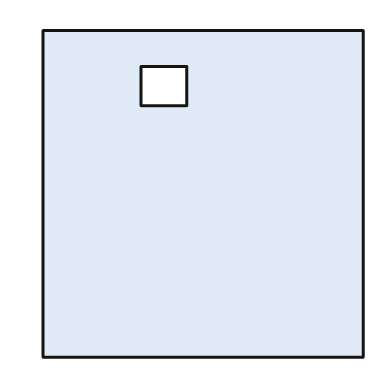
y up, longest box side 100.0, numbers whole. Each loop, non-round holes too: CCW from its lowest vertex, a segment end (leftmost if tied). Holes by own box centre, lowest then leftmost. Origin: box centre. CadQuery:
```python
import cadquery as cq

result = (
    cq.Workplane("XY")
    .moveTo(-49.0, -50.0)
    .lineTo(49.0, -50.0)
    .lineTo(49.0, 50.0)
    .lineTo(-49.0, 50.0)
    .close()
    .moveTo(-19.0, 27.0)
    .lineTo(-5.0, 27.0)
    .lineTo(-5.0, 39.0)
    .lineTo(-19.0, 39.0)
    .close()
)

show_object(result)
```